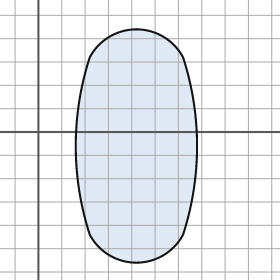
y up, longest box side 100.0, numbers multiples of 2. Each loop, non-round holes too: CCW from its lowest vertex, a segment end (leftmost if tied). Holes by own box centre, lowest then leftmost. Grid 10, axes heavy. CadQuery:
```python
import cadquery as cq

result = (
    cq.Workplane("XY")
    .moveTo(22.0, -44.0)
    .threePointArc((42.0, -56.0), (62.0, -44.0))
    .threePointArc((68.0, -6.0), (62.0, 32.0))
    .threePointArc((42.0, 44.0), (22.0, 32.0))
    .threePointArc((16.0, -6.0), (22.0, -44.0))
    .close()
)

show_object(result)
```